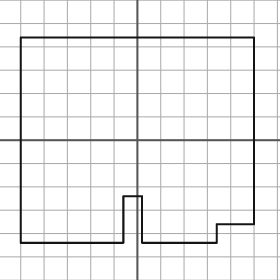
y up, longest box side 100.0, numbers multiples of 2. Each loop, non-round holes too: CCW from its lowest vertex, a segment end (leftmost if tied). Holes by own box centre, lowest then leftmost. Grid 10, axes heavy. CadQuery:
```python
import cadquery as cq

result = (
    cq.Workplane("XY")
    .moveTo(-50.0, -44.0)
    .lineTo(-6.0, -44.0)
    .lineTo(-6.0, -24.0)
    .lineTo(2.0, -24.0)
    .lineTo(2.0, -44.0)
    .lineTo(34.0, -44.0)
    .lineTo(34.0, -36.0)
    .lineTo(50.0, -36.0)
    .lineTo(50.0, 44.0)
    .lineTo(-50.0, 44.0)
    .close()
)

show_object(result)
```